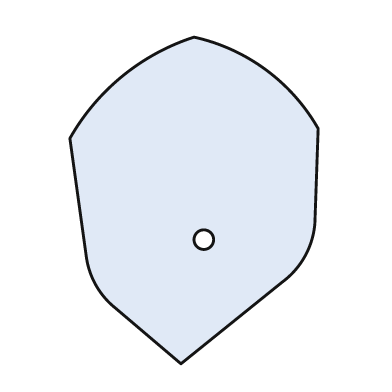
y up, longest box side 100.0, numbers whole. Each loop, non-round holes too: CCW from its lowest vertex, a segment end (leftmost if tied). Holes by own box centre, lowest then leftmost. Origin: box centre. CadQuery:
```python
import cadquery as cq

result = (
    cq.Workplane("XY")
    .moveTo(-4.0, -50.0)
    .lineTo(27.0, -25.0)
    .threePointArc((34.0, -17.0), (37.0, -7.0))
    .lineTo(38.0, 22.0)
    .threePointArc((22.0, 40.0), (0.0, 50.0))
    .threePointArc((-22.0, 38.0), (-38.0, 19.0))
    .lineTo(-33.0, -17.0)
    .threePointArc((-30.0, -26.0), (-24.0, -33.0))
    .close()
    .moveTo(3.0, -12.0)
    .circle(3.0)
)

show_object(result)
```